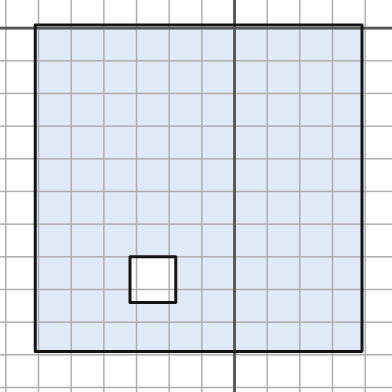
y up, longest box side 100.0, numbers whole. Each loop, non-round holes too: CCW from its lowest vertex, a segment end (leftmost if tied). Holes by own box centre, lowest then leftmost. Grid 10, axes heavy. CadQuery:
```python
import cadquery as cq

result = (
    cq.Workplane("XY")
    .moveTo(-61.0, -99.0)
    .lineTo(39.0, -99.0)
    .lineTo(39.0, 1.0)
    .lineTo(-61.0, 1.0)
    .close()
    .moveTo(-32.0, -84.0)
    .lineTo(-18.0, -84.0)
    .lineTo(-18.0, -70.0)
    .lineTo(-32.0, -70.0)
    .close()
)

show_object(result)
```